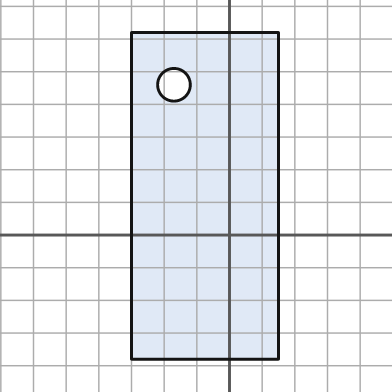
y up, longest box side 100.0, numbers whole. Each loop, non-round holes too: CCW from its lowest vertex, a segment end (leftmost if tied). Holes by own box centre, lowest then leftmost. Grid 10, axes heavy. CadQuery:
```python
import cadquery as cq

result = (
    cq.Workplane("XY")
    .moveTo(-30.0, -38.0)
    .lineTo(15.0, -38.0)
    .lineTo(15.0, 62.0)
    .lineTo(-30.0, 62.0)
    .close()
    .moveTo(-17.0, 46.0)
    .circle(5.0)
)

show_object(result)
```